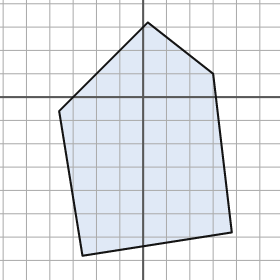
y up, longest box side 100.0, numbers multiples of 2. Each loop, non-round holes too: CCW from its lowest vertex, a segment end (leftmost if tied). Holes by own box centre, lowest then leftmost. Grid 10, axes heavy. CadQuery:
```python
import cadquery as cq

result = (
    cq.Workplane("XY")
    .moveTo(-26.0, -68.0)
    .lineTo(38.0, -58.0)
    .lineTo(30.0, 10.0)
    .lineTo(2.0, 32.0)
    .lineTo(-36.0, -6.0)
    .close()
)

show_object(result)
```